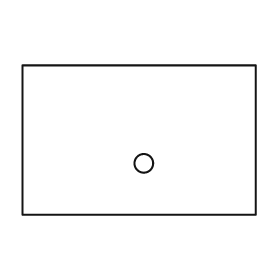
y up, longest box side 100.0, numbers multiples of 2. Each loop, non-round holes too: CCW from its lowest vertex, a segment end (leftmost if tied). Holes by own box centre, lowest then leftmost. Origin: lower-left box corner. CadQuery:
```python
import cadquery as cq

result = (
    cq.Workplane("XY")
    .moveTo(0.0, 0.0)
    .lineTo(100.0, 0.0)
    .lineTo(100.0, 64.0)
    .lineTo(0.0, 64.0)
    .close()
    .moveTo(52.0, 22.0)
    .circle(4.0)
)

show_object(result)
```